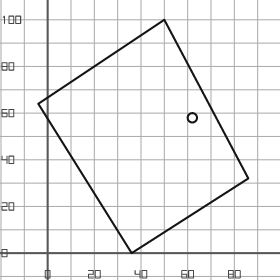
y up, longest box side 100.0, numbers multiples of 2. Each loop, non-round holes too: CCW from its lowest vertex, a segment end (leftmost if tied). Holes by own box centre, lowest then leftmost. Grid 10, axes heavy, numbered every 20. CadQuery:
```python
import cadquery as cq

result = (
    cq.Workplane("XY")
    .moveTo(36.0, 0.0)
    .lineTo(86.0, 32.0)
    .lineTo(50.0, 100.0)
    .lineTo(-4.0, 64.0)
    .close()
    .moveTo(62.0, 58.0)
    .circle(2.0)
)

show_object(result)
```